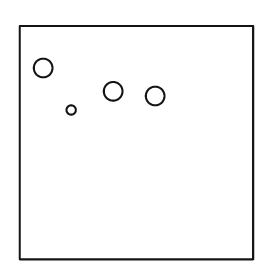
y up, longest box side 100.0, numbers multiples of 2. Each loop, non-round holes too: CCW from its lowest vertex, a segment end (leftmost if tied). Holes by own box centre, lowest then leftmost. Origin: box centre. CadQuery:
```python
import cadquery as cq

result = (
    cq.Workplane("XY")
    .moveTo(-50.0, -50.0)
    .lineTo(50.0, -50.0)
    .lineTo(50.0, 50.0)
    .lineTo(-50.0, 50.0)
    .close()
    .moveTo(-28.0, 14.0)
    .circle(2.0)
    .moveTo(8.0, 20.0)
    .circle(4.0)
    .moveTo(-10.0, 22.0)
    .circle(4.0)
    .moveTo(-40.0, 32.0)
    .circle(4.0)
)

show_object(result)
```